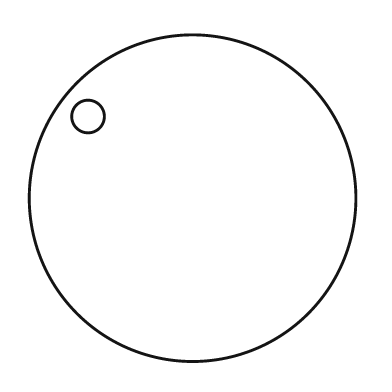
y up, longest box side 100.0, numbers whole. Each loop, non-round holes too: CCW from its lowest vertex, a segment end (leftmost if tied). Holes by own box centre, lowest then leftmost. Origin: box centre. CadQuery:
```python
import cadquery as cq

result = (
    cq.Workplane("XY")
    .moveTo(0.0, 0.0)
    .circle(50.0)
    .moveTo(-32.0, 25.0)
    .circle(5.0)
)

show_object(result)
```